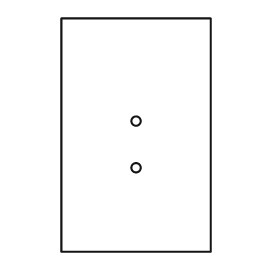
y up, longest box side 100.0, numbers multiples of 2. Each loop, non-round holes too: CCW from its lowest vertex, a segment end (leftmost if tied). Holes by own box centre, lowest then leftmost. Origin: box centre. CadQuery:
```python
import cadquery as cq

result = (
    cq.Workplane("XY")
    .moveTo(-32.0, -50.0)
    .lineTo(32.0, -50.0)
    .lineTo(32.0, 50.0)
    .lineTo(-32.0, 50.0)
    .close()
    .moveTo(0.0, -14.0)
    .circle(2.0)
    .moveTo(0.0, 6.0)
    .circle(2.0)
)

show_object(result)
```